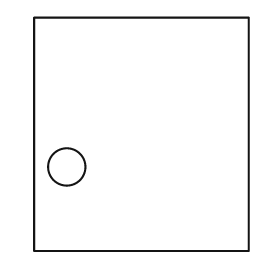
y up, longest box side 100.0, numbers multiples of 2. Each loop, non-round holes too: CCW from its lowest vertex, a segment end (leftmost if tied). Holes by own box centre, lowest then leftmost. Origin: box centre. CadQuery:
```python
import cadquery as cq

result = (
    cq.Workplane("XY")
    .moveTo(-46.0, -50.0)
    .lineTo(46.0, -50.0)
    .lineTo(46.0, 50.0)
    .lineTo(-46.0, 50.0)
    .close()
    .moveTo(-32.0, -14.0)
    .circle(8.0)
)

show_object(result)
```